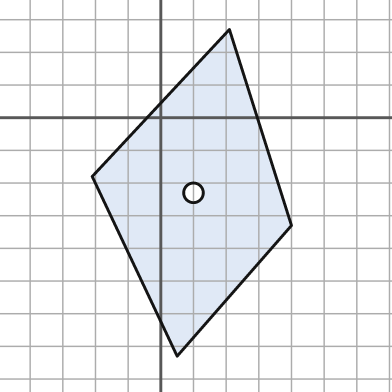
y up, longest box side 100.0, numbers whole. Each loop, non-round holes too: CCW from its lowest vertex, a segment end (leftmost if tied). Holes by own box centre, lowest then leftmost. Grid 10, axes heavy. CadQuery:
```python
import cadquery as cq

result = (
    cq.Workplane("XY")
    .moveTo(5.0, -73.0)
    .lineTo(40.0, -33.0)
    .lineTo(21.0, 27.0)
    .lineTo(-21.0, -18.0)
    .close()
    .moveTo(10.0, -23.0)
    .circle(3.0)
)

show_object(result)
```